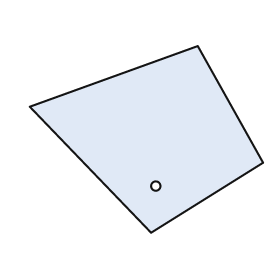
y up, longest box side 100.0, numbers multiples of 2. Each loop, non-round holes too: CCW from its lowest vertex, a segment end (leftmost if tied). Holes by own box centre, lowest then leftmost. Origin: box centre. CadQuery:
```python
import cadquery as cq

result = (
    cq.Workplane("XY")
    .moveTo(2.0, -40.0)
    .lineTo(50.0, -10.0)
    .lineTo(22.0, 40.0)
    .lineTo(-50.0, 14.0)
    .close()
    .moveTo(4.0, -20.0)
    .circle(2.0)
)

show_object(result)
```